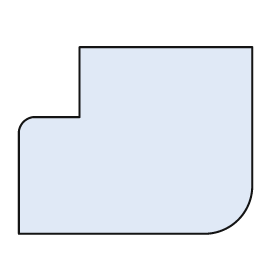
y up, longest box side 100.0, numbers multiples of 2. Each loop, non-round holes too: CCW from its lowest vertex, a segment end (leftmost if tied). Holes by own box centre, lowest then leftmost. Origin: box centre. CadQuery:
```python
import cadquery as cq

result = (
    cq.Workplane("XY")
    .moveTo(-50.0, -40.0)
    .lineTo(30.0, -40.0)
    .threePointArc((44.0, -34.0), (50.0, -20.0))
    .lineTo(50.0, 40.0)
    .lineTo(-24.0, 40.0)
    .lineTo(-24.0, 10.0)
    .lineTo(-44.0, 10.0)
    .threePointArc((-48.0, 8.0), (-50.0, 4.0))
    .close()
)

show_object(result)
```